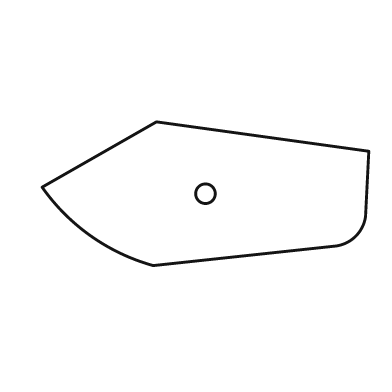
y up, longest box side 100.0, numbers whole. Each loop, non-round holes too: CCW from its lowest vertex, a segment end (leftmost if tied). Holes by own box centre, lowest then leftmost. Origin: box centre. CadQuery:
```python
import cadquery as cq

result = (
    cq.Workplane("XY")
    .moveTo(-16.0, -22.0)
    .lineTo(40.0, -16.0)
    .threePointArc((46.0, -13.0), (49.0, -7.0))
    .lineTo(50.0, 13.0)
    .lineTo(-15.0, 22.0)
    .lineTo(-50.0, 2.0)
    .threePointArc((-35.0, -13.0), (-16.0, -22.0))
    .close()
    .moveTo(0.0, 0.0)
    .circle(3.0)
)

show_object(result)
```